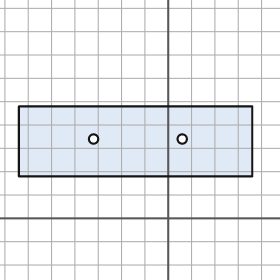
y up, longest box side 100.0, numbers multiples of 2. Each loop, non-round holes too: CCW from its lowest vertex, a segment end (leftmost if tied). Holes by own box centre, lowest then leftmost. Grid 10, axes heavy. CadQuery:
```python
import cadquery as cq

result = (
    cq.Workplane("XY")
    .moveTo(-64.0, 18.0)
    .lineTo(36.0, 18.0)
    .lineTo(36.0, 48.0)
    .lineTo(-64.0, 48.0)
    .close()
    .moveTo(-32.0, 34.0)
    .circle(2.0)
    .moveTo(6.0, 34.0)
    .circle(2.0)
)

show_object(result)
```